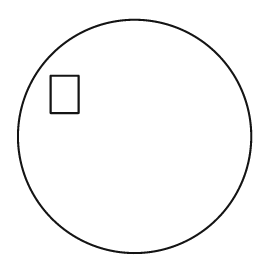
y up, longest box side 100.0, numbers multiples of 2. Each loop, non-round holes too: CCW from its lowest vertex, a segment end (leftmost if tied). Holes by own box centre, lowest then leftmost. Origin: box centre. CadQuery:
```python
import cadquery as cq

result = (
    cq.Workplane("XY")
    .moveTo(0.0, 0.0)
    .circle(50.0)
    .moveTo(-36.0, 10.0)
    .lineTo(-24.0, 10.0)
    .lineTo(-24.0, 26.0)
    .lineTo(-36.0, 26.0)
    .close()
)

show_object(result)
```